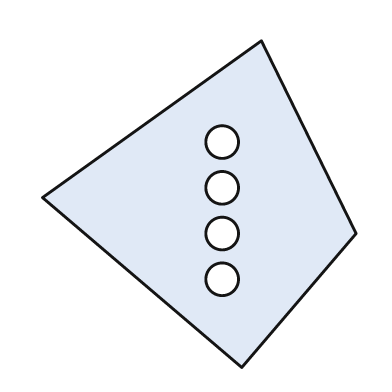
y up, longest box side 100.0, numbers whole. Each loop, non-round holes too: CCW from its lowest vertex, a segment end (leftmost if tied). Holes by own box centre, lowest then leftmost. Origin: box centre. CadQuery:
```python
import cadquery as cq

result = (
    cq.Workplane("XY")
    .moveTo(13.0, -50.0)
    .lineTo(48.0, -9.0)
    .lineTo(19.0, 50.0)
    .lineTo(-48.0, 2.0)
    .close()
    .moveTo(7.0, -23.0)
    .circle(5.0)
    .moveTo(7.0, -9.0)
    .circle(5.0)
    .moveTo(7.0, 5.0)
    .circle(5.0)
    .moveTo(7.0, 19.0)
    .circle(5.0)
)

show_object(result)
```